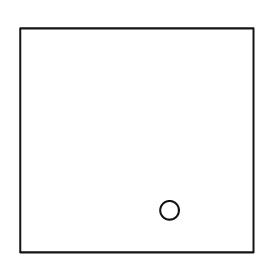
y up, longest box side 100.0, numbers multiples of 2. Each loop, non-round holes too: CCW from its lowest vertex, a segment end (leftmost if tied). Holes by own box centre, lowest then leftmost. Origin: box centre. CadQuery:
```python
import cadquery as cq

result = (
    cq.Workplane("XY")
    .moveTo(-50.0, -48.0)
    .lineTo(50.0, -48.0)
    .lineTo(50.0, 48.0)
    .lineTo(-50.0, 48.0)
    .close()
    .moveTo(14.0, -30.0)
    .circle(4.0)
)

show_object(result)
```